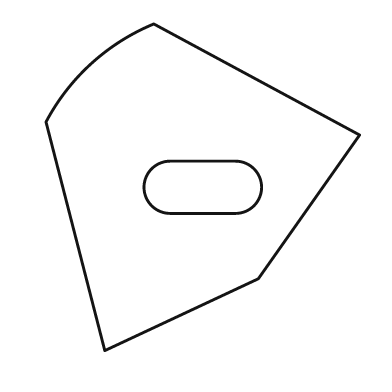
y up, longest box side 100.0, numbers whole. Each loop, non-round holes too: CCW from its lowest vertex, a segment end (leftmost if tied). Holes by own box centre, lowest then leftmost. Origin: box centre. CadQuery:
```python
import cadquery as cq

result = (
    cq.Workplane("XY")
    .moveTo(-30.0, -50.0)
    .lineTo(17.0, -28.0)
    .lineTo(48.0, 16.0)
    .lineTo(-15.0, 50.0)
    .threePointArc((-34.0, 38.0), (-48.0, 20.0))
    .close()
    .moveTo(-10.0, -8.0)
    .lineTo(10.0, -8.0)
    .threePointArc((18.0, 0.0), (10.0, 8.0))
    .lineTo(-10.0, 8.0)
    .threePointArc((-18.0, 0.0), (-10.0, -8.0))
    .close()
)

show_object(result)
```